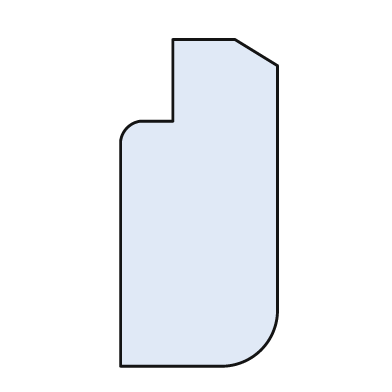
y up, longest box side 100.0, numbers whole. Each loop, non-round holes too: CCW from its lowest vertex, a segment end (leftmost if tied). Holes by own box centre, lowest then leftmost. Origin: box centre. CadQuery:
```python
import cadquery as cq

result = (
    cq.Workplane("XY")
    .moveTo(-24.0, -50.0)
    .lineTo(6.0, -50.0)
    .threePointArc((19.0, -45.0), (24.0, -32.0))
    .lineTo(24.0, 42.0)
    .lineTo(11.0, 50.0)
    .lineTo(-8.0, 50.0)
    .lineTo(-8.0, 25.0)
    .lineTo(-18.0, 25.0)
    .threePointArc((-22.0, 23.0), (-24.0, 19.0))
    .close()
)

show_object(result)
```